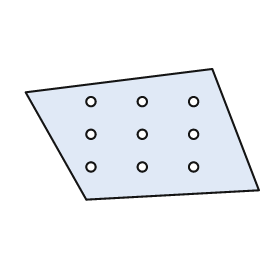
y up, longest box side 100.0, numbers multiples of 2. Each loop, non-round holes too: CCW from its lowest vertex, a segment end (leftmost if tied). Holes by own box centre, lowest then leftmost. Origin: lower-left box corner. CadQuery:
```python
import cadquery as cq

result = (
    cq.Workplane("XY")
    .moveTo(26.0, 0.0)
    .lineTo(100.0, 4.0)
    .lineTo(80.0, 56.0)
    .lineTo(0.0, 46.0)
    .close()
    .moveTo(28.0, 14.0)
    .circle(2.0)
    .moveTo(50.0, 14.0)
    .circle(2.0)
    .moveTo(72.0, 14.0)
    .circle(2.0)
    .moveTo(28.0, 28.0)
    .circle(2.0)
    .moveTo(50.0, 28.0)
    .circle(2.0)
    .moveTo(72.0, 28.0)
    .circle(2.0)
    .moveTo(28.0, 42.0)
    .circle(2.0)
    .moveTo(50.0, 42.0)
    .circle(2.0)
    .moveTo(72.0, 42.0)
    .circle(2.0)
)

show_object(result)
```